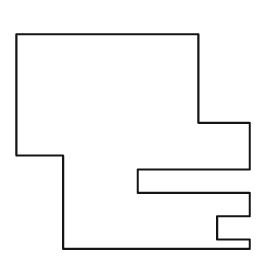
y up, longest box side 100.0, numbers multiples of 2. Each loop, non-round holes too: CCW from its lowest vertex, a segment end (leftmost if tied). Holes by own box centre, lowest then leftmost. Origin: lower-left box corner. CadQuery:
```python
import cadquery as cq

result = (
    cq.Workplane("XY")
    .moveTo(20.0, 0.0)
    .lineTo(100.0, 0.0)
    .lineTo(100.0, 4.0)
    .lineTo(86.0, 4.0)
    .lineTo(86.0, 14.0)
    .lineTo(100.0, 14.0)
    .lineTo(100.0, 24.0)
    .lineTo(52.0, 24.0)
    .lineTo(52.0, 34.0)
    .lineTo(100.0, 34.0)
    .lineTo(100.0, 54.0)
    .lineTo(78.0, 54.0)
    .lineTo(78.0, 92.0)
    .lineTo(0.0, 92.0)
    .lineTo(0.0, 40.0)
    .lineTo(20.0, 40.0)
    .close()
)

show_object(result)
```